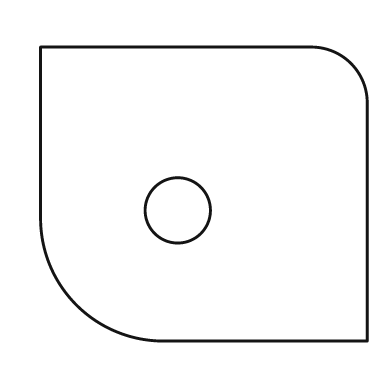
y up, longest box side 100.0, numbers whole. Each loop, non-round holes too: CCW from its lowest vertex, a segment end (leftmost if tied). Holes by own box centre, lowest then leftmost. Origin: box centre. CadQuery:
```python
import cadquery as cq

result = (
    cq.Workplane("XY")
    .moveTo(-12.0, -45.0)
    .lineTo(50.0, -45.0)
    .lineTo(50.0, 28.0)
    .threePointArc((45.0, 40.0), (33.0, 45.0))
    .lineTo(-50.0, 45.0)
    .lineTo(-50.0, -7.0)
    .threePointArc((-39.0, -34.0), (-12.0, -45.0))
    .close()
    .moveTo(-8.0, -5.0)
    .circle(10.0)
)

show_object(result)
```